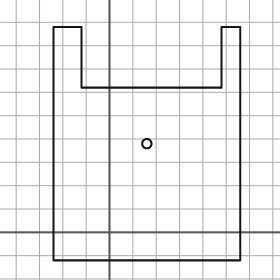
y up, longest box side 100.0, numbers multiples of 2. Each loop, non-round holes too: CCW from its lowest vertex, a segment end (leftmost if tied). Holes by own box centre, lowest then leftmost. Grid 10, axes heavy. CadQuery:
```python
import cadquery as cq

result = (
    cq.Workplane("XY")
    .moveTo(-24.0, -12.0)
    .lineTo(56.0, -12.0)
    .lineTo(56.0, 88.0)
    .lineTo(48.0, 88.0)
    .lineTo(48.0, 62.0)
    .lineTo(-12.0, 62.0)
    .lineTo(-12.0, 88.0)
    .lineTo(-24.0, 88.0)
    .close()
    .moveTo(16.0, 38.0)
    .circle(2.0)
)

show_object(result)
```